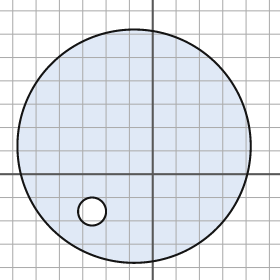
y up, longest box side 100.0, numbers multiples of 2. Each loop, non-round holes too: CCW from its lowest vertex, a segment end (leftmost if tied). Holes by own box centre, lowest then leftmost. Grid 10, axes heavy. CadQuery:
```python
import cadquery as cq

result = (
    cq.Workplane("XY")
    .moveTo(-8.0, 12.0)
    .circle(50.0)
    .moveTo(-26.0, -16.0)
    .circle(6.0)
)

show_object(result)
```